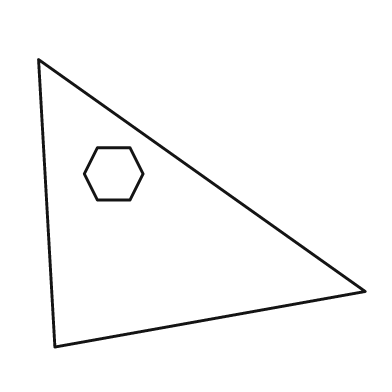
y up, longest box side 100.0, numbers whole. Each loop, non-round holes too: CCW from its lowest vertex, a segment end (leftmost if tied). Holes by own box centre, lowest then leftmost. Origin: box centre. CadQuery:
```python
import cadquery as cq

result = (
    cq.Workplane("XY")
    .moveTo(-45.0, -44.0)
    .lineTo(50.0, -27.0)
    .lineTo(-50.0, 44.0)
    .close()
    .moveTo(-32.0, 1.0)
    .lineTo(-22.0, 1.0)
    .lineTo(-18.0, 9.0)
    .lineTo(-22.0, 17.0)
    .lineTo(-32.0, 17.0)
    .lineTo(-36.0, 9.0)
    .close()
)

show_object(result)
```